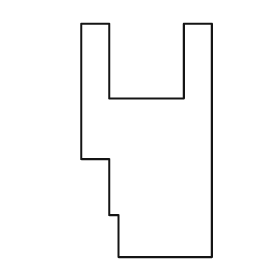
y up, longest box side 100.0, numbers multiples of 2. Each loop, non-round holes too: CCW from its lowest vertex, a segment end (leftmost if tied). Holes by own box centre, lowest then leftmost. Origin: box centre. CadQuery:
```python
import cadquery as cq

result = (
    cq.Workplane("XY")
    .moveTo(-12.0, -50.0)
    .lineTo(28.0, -50.0)
    .lineTo(28.0, 50.0)
    .lineTo(16.0, 50.0)
    .lineTo(16.0, 18.0)
    .lineTo(-16.0, 18.0)
    .lineTo(-16.0, 50.0)
    .lineTo(-28.0, 50.0)
    .lineTo(-28.0, -8.0)
    .lineTo(-16.0, -8.0)
    .lineTo(-16.0, -32.0)
    .lineTo(-12.0, -32.0)
    .close()
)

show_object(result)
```